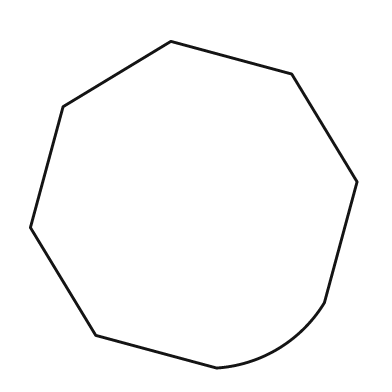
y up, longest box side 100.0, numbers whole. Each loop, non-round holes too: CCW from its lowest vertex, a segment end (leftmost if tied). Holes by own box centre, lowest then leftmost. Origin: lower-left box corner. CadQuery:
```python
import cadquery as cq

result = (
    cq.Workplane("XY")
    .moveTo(57.0, 0.0)
    .threePointArc((76.0, 6.0), (90.0, 20.0))
    .lineTo(100.0, 57.0)
    .lineTo(80.0, 90.0)
    .lineTo(43.0, 100.0)
    .lineTo(10.0, 80.0)
    .lineTo(0.0, 43.0)
    .lineTo(20.0, 10.0)
    .close()
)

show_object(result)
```